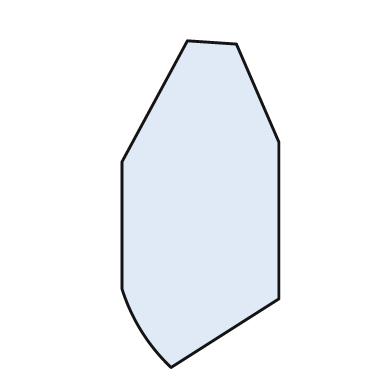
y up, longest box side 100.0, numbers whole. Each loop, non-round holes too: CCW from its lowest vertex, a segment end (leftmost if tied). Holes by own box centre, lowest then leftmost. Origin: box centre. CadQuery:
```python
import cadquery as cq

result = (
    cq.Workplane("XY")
    .moveTo(-9.0, -50.0)
    .lineTo(24.0, -29.0)
    .lineTo(24.0, 19.0)
    .lineTo(11.0, 49.0)
    .lineTo(-4.0, 50.0)
    .lineTo(-24.0, 13.0)
    .lineTo(-24.0, -26.0)
    .threePointArc((-18.0, -39.0), (-9.0, -50.0))
    .close()
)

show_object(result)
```